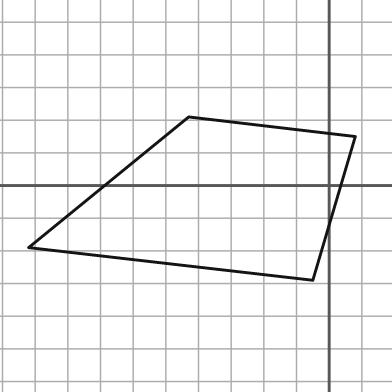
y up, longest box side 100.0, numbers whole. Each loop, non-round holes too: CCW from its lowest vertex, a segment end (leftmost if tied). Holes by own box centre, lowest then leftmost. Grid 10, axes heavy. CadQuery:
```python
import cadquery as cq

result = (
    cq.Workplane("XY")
    .moveTo(-5.0, -29.0)
    .lineTo(8.0, 15.0)
    .lineTo(-43.0, 21.0)
    .lineTo(-92.0, -19.0)
    .close()
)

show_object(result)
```